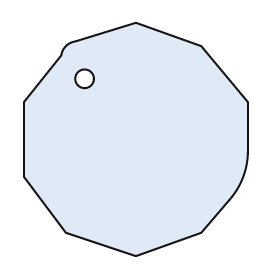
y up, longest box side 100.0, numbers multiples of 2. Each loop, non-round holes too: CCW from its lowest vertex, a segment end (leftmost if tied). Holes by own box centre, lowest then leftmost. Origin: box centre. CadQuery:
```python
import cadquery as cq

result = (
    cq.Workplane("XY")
    .moveTo(0.0, -50.0)
    .lineTo(28.0, -40.0)
    .lineTo(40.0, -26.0)
    .threePointArc((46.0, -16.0), (48.0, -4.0))
    .lineTo(48.0, 16.0)
    .lineTo(28.0, 40.0)
    .lineTo(0.0, 50.0)
    .lineTo(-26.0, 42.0)
    .threePointArc((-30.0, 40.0), (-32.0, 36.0))
    .lineTo(-48.0, 16.0)
    .lineTo(-48.0, -16.0)
    .lineTo(-30.0, -40.0)
    .close()
    .moveTo(-22.0, 26.0)
    .circle(4.0)
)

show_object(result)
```